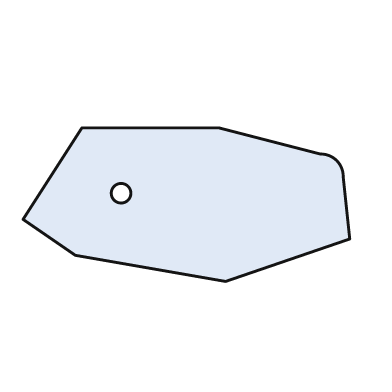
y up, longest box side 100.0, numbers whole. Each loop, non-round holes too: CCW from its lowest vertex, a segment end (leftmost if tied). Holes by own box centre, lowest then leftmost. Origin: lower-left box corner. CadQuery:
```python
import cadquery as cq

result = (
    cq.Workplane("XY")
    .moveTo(62.0, 0.0)
    .lineTo(100.0, 13.0)
    .lineTo(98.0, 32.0)
    .threePointArc((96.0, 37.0), (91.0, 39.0))
    .lineTo(60.0, 47.0)
    .lineTo(18.0, 47.0)
    .lineTo(0.0, 19.0)
    .lineTo(16.0, 8.0)
    .close()
    .moveTo(30.0, 27.0)
    .circle(3.0)
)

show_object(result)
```